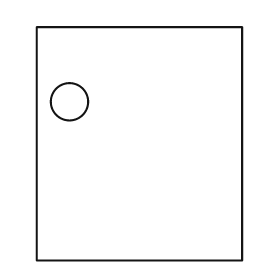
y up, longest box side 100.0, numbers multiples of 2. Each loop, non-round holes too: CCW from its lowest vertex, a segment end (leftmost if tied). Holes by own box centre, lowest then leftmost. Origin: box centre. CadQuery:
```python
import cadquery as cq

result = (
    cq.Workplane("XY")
    .moveTo(-44.0, -50.0)
    .lineTo(44.0, -50.0)
    .lineTo(44.0, 50.0)
    .lineTo(-44.0, 50.0)
    .close()
    .moveTo(-30.0, 18.0)
    .circle(8.0)
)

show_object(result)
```